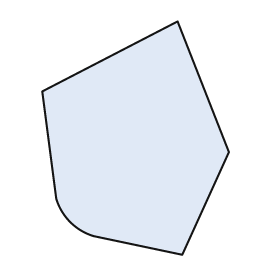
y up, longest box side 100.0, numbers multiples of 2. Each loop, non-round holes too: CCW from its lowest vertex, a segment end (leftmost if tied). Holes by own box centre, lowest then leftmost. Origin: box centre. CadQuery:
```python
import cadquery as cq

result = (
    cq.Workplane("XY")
    .moveTo(20.0, -50.0)
    .lineTo(40.0, -6.0)
    .lineTo(18.0, 50.0)
    .lineTo(-40.0, 20.0)
    .lineTo(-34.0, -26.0)
    .threePointArc((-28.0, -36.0), (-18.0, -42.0))
    .close()
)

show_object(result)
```